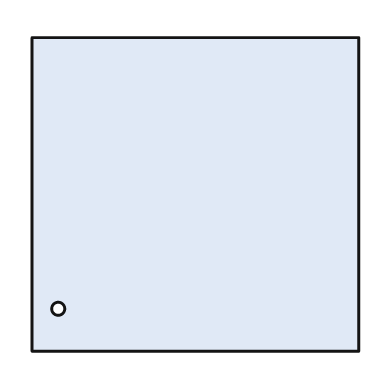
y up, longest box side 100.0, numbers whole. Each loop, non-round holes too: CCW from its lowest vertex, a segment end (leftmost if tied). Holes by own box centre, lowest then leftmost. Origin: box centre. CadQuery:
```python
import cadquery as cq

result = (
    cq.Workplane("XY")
    .moveTo(-50.0, -48.0)
    .lineTo(50.0, -48.0)
    .lineTo(50.0, 48.0)
    .lineTo(-50.0, 48.0)
    .close()
    .moveTo(-42.0, -35.0)
    .circle(2.0)
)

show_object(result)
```